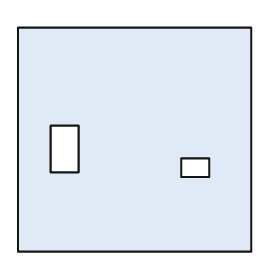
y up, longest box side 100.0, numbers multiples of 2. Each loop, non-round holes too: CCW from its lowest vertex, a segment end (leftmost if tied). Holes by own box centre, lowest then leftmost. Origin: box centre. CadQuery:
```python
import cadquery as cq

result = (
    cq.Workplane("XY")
    .moveTo(-50.0, -48.0)
    .lineTo(50.0, -48.0)
    .lineTo(50.0, 48.0)
    .lineTo(-50.0, 48.0)
    .close()
    .moveTo(20.0, -16.0)
    .lineTo(32.0, -16.0)
    .lineTo(32.0, -8.0)
    .lineTo(20.0, -8.0)
    .close()
    .moveTo(-36.0, -14.0)
    .lineTo(-24.0, -14.0)
    .lineTo(-24.0, 6.0)
    .lineTo(-36.0, 6.0)
    .close()
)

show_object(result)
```